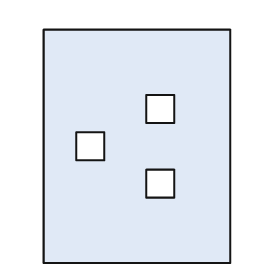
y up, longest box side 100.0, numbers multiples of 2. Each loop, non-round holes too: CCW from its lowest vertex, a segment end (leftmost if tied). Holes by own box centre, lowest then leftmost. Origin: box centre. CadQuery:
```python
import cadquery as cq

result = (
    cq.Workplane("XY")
    .moveTo(-40.0, -50.0)
    .lineTo(40.0, -50.0)
    .lineTo(40.0, 50.0)
    .lineTo(-40.0, 50.0)
    .close()
    .moveTo(4.0, -22.0)
    .lineTo(16.0, -22.0)
    .lineTo(16.0, -10.0)
    .lineTo(4.0, -10.0)
    .close()
    .moveTo(-26.0, -6.0)
    .lineTo(-14.0, -6.0)
    .lineTo(-14.0, 6.0)
    .lineTo(-26.0, 6.0)
    .close()
    .moveTo(4.0, 10.0)
    .lineTo(16.0, 10.0)
    .lineTo(16.0, 22.0)
    .lineTo(4.0, 22.0)
    .close()
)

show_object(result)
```